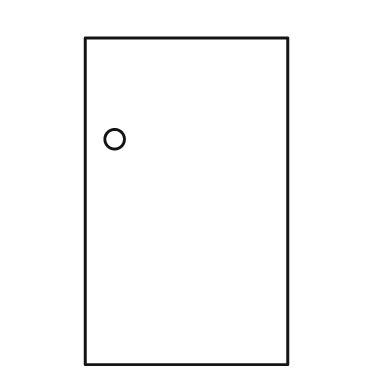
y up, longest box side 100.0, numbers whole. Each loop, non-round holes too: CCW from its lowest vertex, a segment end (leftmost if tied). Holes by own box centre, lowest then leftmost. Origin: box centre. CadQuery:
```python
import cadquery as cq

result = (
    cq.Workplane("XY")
    .moveTo(-31.0, -50.0)
    .lineTo(31.0, -50.0)
    .lineTo(31.0, 50.0)
    .lineTo(-31.0, 50.0)
    .close()
    .moveTo(-22.0, 19.0)
    .circle(3.0)
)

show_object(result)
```